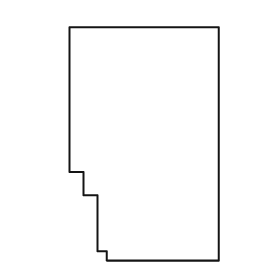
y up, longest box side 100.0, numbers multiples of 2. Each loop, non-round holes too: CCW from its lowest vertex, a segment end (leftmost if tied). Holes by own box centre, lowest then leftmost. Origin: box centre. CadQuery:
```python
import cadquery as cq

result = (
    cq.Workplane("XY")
    .moveTo(-16.0, -50.0)
    .lineTo(32.0, -50.0)
    .lineTo(32.0, 50.0)
    .lineTo(-32.0, 50.0)
    .lineTo(-32.0, -12.0)
    .lineTo(-26.0, -12.0)
    .lineTo(-26.0, -22.0)
    .lineTo(-20.0, -22.0)
    .lineTo(-20.0, -46.0)
    .lineTo(-16.0, -46.0)
    .close()
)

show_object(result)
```